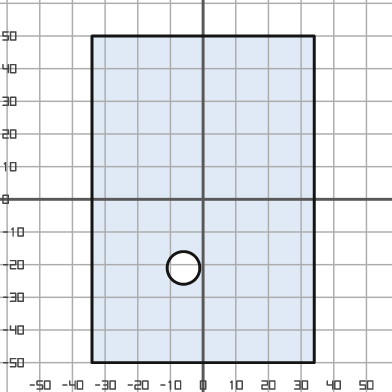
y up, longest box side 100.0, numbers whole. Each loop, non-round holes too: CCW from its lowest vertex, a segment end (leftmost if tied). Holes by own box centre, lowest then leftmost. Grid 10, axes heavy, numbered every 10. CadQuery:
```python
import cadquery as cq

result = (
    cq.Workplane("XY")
    .moveTo(-34.0, -50.0)
    .lineTo(34.0, -50.0)
    .lineTo(34.0, 50.0)
    .lineTo(-34.0, 50.0)
    .close()
    .moveTo(-6.0, -21.0)
    .circle(5.0)
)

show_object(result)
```